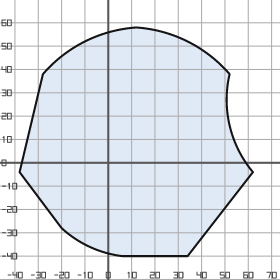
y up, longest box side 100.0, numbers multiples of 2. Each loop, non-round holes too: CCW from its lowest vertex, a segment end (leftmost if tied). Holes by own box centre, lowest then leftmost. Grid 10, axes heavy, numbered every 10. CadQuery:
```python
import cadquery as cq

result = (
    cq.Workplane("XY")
    .moveTo(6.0, -40.0)
    .lineTo(34.0, -40.0)
    .lineTo(62.0, -4.0)
    .threePointArc((52.0, 16.0), (52.0, 38.0))
    .threePointArc((34.0, 52.0), (12.0, 58.0))
    .threePointArc((-10.0, 52.0), (-28.0, 38.0))
    .lineTo(-38.0, -4.0)
    .lineTo(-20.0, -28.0)
    .threePointArc((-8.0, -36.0), (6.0, -40.0))
    .close()
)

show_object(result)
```